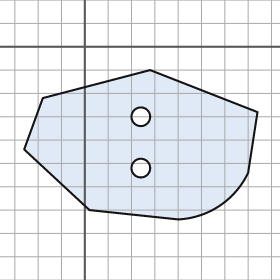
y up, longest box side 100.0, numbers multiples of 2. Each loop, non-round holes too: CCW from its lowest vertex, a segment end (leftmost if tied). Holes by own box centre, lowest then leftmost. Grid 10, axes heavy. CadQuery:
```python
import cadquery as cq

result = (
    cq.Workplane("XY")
    .moveTo(40.0, -74.0)
    .threePointArc((58.0, -68.0), (70.0, -54.0))
    .lineTo(74.0, -28.0)
    .lineTo(28.0, -10.0)
    .lineTo(-18.0, -22.0)
    .lineTo(-26.0, -44.0)
    .lineTo(2.0, -70.0)
    .close()
    .moveTo(24.0, -52.0)
    .circle(4.0)
    .moveTo(24.0, -30.0)
    .circle(4.0)
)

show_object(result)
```